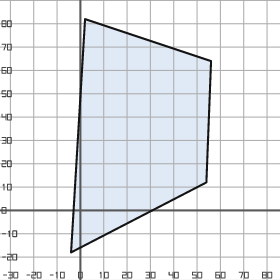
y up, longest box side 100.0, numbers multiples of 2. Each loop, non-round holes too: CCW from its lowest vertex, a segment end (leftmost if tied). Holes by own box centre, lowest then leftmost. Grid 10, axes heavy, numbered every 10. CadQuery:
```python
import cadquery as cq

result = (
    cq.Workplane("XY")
    .moveTo(-4.0, -18.0)
    .lineTo(54.0, 12.0)
    .lineTo(56.0, 64.0)
    .lineTo(2.0, 82.0)
    .close()
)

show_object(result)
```